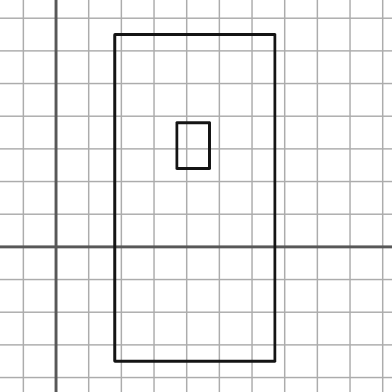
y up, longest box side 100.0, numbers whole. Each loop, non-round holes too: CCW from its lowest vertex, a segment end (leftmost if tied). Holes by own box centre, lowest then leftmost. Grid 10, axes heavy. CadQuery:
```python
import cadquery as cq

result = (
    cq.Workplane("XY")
    .moveTo(18.0, -35.0)
    .lineTo(67.0, -35.0)
    .lineTo(67.0, 65.0)
    .lineTo(18.0, 65.0)
    .close()
    .moveTo(37.0, 24.0)
    .lineTo(47.0, 24.0)
    .lineTo(47.0, 38.0)
    .lineTo(37.0, 38.0)
    .close()
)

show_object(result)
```